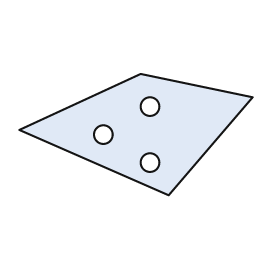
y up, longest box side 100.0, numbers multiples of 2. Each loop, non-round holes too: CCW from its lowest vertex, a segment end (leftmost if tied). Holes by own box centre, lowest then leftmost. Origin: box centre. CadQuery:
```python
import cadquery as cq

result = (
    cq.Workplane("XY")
    .moveTo(14.0, -26.0)
    .lineTo(50.0, 16.0)
    .lineTo(2.0, 26.0)
    .lineTo(-50.0, 2.0)
    .close()
    .moveTo(6.0, -12.0)
    .circle(4.0)
    .moveTo(-14.0, 0.0)
    .circle(4.0)
    .moveTo(6.0, 12.0)
    .circle(4.0)
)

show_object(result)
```